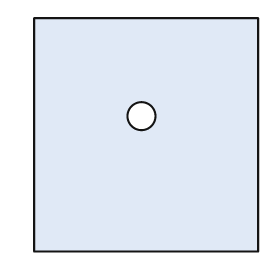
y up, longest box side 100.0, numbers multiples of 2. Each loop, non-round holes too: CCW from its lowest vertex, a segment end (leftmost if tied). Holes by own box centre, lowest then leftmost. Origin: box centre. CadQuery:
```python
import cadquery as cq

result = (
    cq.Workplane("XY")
    .moveTo(-48.0, -50.0)
    .lineTo(48.0, -50.0)
    .lineTo(48.0, 50.0)
    .lineTo(-48.0, 50.0)
    .close()
    .moveTo(-2.0, 8.0)
    .circle(6.0)
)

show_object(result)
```